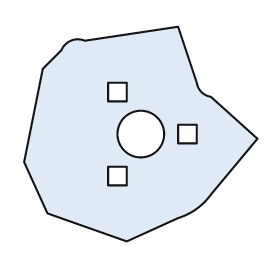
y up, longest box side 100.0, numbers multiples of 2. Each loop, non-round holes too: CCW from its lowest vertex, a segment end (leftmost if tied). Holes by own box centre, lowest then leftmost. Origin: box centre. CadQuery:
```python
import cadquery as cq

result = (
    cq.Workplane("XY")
    .moveTo(-6.0, -46.0)
    .lineTo(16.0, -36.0)
    .threePointArc((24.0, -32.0), (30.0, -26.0))
    .lineTo(50.0, -2.0)
    .lineTo(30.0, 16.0)
    .threePointArc((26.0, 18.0), (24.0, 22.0))
    .lineTo(16.0, 46.0)
    .lineTo(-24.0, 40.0)
    .threePointArc((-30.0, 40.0), (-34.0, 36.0))
    .lineTo(-42.0, 28.0)
    .lineTo(-50.0, -12.0)
    .lineTo(-40.0, -34.0)
    .close()
    .moveTo(-14.0, -22.0)
    .lineTo(-6.0, -22.0)
    .lineTo(-6.0, -14.0)
    .lineTo(-14.0, -14.0)
    .close()
    .moveTo(0.0, 0.0)
    .circle(10.0)
    .moveTo(16.0, -4.0)
    .lineTo(24.0, -4.0)
    .lineTo(24.0, 4.0)
    .lineTo(16.0, 4.0)
    .close()
    .moveTo(-14.0, 14.0)
    .lineTo(-6.0, 14.0)
    .lineTo(-6.0, 22.0)
    .lineTo(-14.0, 22.0)
    .close()
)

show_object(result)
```